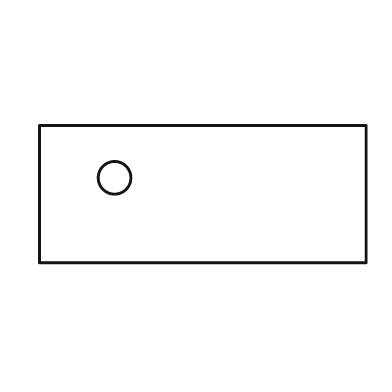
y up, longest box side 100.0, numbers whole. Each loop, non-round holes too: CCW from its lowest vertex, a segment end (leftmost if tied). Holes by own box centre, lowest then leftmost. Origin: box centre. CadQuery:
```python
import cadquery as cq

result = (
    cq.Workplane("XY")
    .moveTo(-50.0, -21.0)
    .lineTo(50.0, -21.0)
    .lineTo(50.0, 21.0)
    .lineTo(-50.0, 21.0)
    .close()
    .moveTo(-27.0, 5.0)
    .circle(5.0)
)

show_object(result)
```